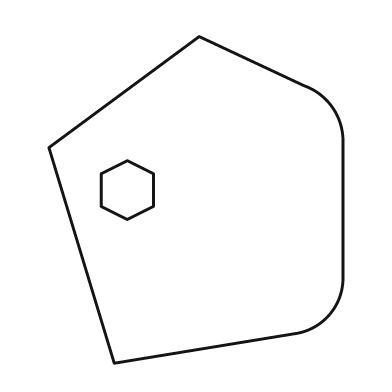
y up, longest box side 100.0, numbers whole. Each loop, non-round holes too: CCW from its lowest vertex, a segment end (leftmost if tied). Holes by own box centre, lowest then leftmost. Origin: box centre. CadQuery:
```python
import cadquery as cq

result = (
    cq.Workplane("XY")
    .moveTo(-25.0, -50.0)
    .lineTo(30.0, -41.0)
    .threePointArc((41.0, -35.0), (45.0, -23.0))
    .lineTo(45.0, 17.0)
    .threePointArc((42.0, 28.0), (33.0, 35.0))
    .lineTo(1.0, 50.0)
    .lineTo(-45.0, 16.0)
    .close()
    .moveTo(-21.0, -6.0)
    .lineTo(-13.0, -2.0)
    .lineTo(-13.0, 8.0)
    .lineTo(-21.0, 12.0)
    .lineTo(-29.0, 8.0)
    .lineTo(-29.0, -2.0)
    .close()
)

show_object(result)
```